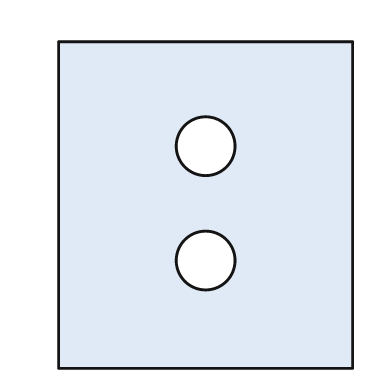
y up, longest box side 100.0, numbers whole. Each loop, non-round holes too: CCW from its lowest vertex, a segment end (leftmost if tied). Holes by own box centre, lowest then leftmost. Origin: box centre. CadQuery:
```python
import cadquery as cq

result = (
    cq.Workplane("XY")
    .moveTo(-45.0, -50.0)
    .lineTo(45.0, -50.0)
    .lineTo(45.0, 50.0)
    .lineTo(-45.0, 50.0)
    .close()
    .moveTo(0.0, -17.0)
    .circle(9.0)
    .moveTo(0.0, 18.0)
    .circle(9.0)
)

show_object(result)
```